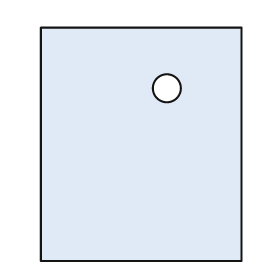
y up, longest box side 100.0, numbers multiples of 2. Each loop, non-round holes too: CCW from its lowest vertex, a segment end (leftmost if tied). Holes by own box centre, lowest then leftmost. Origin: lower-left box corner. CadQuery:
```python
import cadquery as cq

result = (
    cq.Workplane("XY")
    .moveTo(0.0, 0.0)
    .lineTo(86.0, 0.0)
    .lineTo(86.0, 100.0)
    .lineTo(0.0, 100.0)
    .close()
    .moveTo(54.0, 74.0)
    .circle(6.0)
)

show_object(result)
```